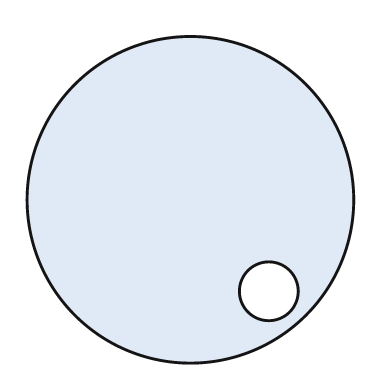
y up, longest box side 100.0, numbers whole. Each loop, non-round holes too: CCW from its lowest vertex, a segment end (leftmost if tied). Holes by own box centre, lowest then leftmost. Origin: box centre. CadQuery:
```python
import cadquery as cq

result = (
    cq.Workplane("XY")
    .moveTo(0.0, 0.0)
    .circle(50.0)
    .moveTo(24.0, -28.0)
    .circle(9.0)
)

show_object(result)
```